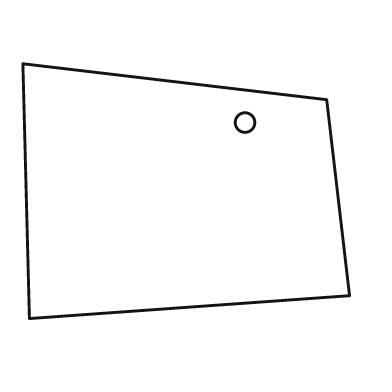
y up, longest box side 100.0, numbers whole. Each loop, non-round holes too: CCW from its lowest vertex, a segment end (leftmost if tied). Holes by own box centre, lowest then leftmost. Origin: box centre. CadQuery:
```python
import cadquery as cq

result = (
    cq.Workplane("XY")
    .moveTo(-48.0, -39.0)
    .lineTo(50.0, -32.0)
    .lineTo(43.0, 28.0)
    .lineTo(-50.0, 39.0)
    .close()
    .moveTo(18.0, 21.0)
    .circle(3.0)
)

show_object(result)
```